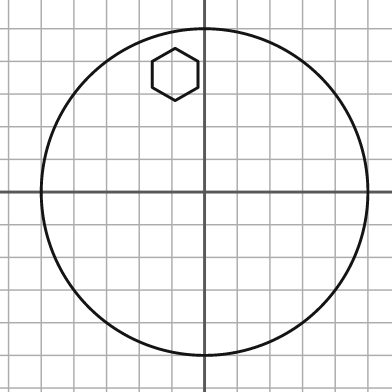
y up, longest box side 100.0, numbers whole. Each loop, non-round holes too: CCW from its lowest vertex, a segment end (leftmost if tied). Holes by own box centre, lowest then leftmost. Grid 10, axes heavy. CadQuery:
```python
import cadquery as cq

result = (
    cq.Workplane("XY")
    .moveTo(0.0, 0.0)
    .circle(50.0)
    .moveTo(-9.0, 28.0)
    .lineTo(-2.0, 32.0)
    .lineTo(-2.0, 40.0)
    .lineTo(-9.0, 44.0)
    .lineTo(-16.0, 40.0)
    .lineTo(-16.0, 32.0)
    .close()
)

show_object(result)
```